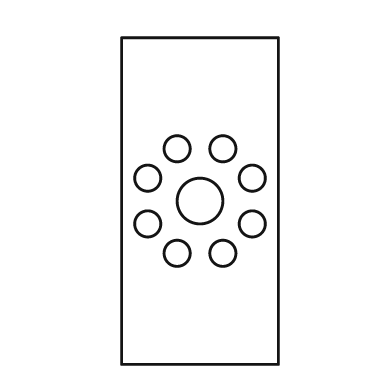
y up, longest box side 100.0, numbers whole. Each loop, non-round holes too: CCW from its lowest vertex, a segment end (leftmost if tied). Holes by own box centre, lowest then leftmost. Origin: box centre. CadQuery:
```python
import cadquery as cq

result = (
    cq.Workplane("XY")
    .moveTo(-24.0, -50.0)
    .lineTo(24.0, -50.0)
    .lineTo(24.0, 50.0)
    .lineTo(-24.0, 50.0)
    .close()
    .moveTo(-7.0, -16.0)
    .circle(4.0)
    .moveTo(7.0, -16.0)
    .circle(4.0)
    .moveTo(-16.0, -7.0)
    .circle(4.0)
    .moveTo(16.0, -7.0)
    .circle(4.0)
    .moveTo(0.0, 0.0)
    .circle(7.0)
    .moveTo(-16.0, 7.0)
    .circle(4.0)
    .moveTo(16.0, 7.0)
    .circle(4.0)
    .moveTo(-7.0, 16.0)
    .circle(4.0)
    .moveTo(7.0, 16.0)
    .circle(4.0)
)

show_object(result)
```